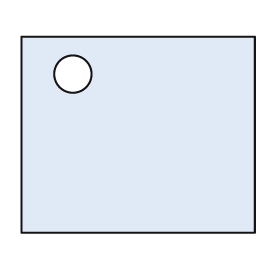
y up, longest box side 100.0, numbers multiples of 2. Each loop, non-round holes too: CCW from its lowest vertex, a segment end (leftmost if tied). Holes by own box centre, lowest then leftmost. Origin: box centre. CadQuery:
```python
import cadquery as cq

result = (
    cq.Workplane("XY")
    .moveTo(-50.0, -42.0)
    .lineTo(50.0, -42.0)
    .lineTo(50.0, 42.0)
    .lineTo(-50.0, 42.0)
    .close()
    .moveTo(-28.0, 26.0)
    .circle(8.0)
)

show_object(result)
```